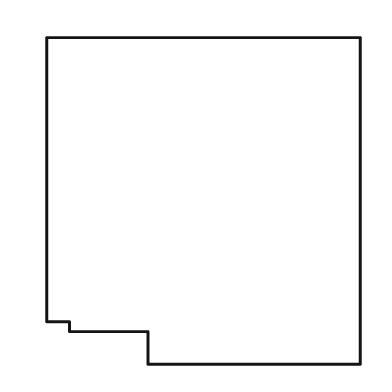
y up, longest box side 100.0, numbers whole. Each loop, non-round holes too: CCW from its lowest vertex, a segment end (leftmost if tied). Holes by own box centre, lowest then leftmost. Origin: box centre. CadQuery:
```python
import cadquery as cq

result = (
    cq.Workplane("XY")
    .moveTo(-17.0, -50.0)
    .lineTo(48.0, -50.0)
    .lineTo(48.0, 50.0)
    .lineTo(-48.0, 50.0)
    .lineTo(-48.0, -37.0)
    .lineTo(-41.0, -37.0)
    .lineTo(-41.0, -40.0)
    .lineTo(-17.0, -40.0)
    .close()
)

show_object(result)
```